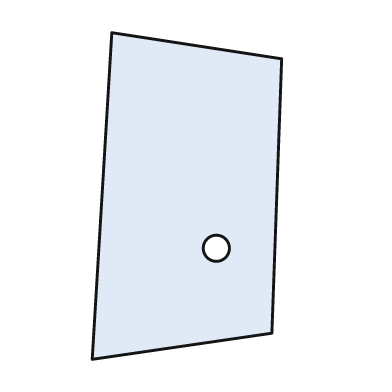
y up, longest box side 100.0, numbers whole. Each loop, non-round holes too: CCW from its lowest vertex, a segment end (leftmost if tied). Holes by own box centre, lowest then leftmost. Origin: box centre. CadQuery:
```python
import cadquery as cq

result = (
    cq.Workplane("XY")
    .moveTo(-29.0, -50.0)
    .lineTo(26.0, -42.0)
    .lineTo(29.0, 42.0)
    .lineTo(-23.0, 50.0)
    .close()
    .moveTo(9.0, -16.0)
    .circle(4.0)
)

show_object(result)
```